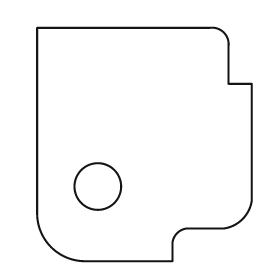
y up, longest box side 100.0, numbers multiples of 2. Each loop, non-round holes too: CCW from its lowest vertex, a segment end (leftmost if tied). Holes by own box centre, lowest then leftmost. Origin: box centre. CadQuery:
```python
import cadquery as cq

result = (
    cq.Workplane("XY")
    .moveTo(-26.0, -50.0)
    .lineTo(12.0, -50.0)
    .lineTo(12.0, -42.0)
    .threePointArc((14.0, -38.0), (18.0, -36.0))
    .lineTo(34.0, -36.0)
    .threePointArc((42.0, -32.0), (46.0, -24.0))
    .lineTo(46.0, 26.0)
    .lineTo(36.0, 26.0)
    .lineTo(36.0, 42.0)
    .threePointArc((34.0, 48.0), (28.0, 50.0))
    .lineTo(-46.0, 50.0)
    .lineTo(-46.0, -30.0)
    .threePointArc((-40.0, -44.0), (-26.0, -50.0))
    .close()
    .moveTo(-20.0, -18.0)
    .circle(10.0)
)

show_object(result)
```